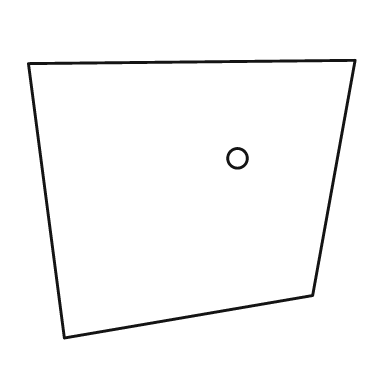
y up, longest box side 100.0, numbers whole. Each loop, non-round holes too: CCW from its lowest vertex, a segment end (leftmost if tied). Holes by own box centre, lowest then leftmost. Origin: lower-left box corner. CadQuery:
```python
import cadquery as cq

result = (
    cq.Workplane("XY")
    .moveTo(11.0, 0.0)
    .lineTo(87.0, 13.0)
    .lineTo(100.0, 85.0)
    .lineTo(0.0, 84.0)
    .close()
    .moveTo(64.0, 55.0)
    .circle(3.0)
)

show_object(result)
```